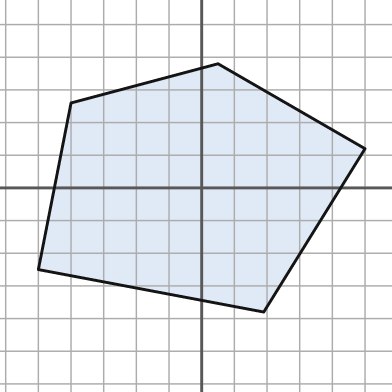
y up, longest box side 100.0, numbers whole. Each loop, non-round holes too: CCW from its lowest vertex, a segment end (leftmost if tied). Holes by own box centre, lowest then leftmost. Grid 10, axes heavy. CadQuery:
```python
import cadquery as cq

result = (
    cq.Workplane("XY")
    .moveTo(19.0, -38.0)
    .lineTo(50.0, 12.0)
    .lineTo(5.0, 38.0)
    .lineTo(-40.0, 26.0)
    .lineTo(-50.0, -25.0)
    .close()
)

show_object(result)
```